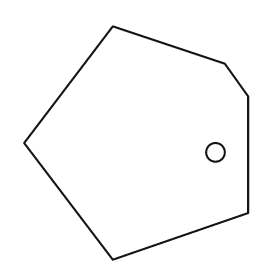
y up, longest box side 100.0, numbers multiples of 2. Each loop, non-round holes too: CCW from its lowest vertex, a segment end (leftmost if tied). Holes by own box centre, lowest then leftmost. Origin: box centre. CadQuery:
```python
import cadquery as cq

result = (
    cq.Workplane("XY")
    .moveTo(-10.0, -50.0)
    .lineTo(48.0, -30.0)
    .lineTo(48.0, 20.0)
    .lineTo(38.0, 34.0)
    .lineTo(-10.0, 50.0)
    .lineTo(-48.0, 0.0)
    .close()
    .moveTo(34.0, -4.0)
    .circle(4.0)
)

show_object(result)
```